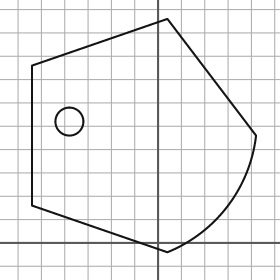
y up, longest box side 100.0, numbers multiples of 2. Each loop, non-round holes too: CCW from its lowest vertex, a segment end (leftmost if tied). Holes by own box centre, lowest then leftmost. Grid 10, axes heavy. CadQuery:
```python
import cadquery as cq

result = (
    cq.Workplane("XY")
    .moveTo(4.0, -4.0)
    .threePointArc((30.0, 16.0), (42.0, 46.0))
    .lineTo(4.0, 96.0)
    .lineTo(-54.0, 76.0)
    .lineTo(-54.0, 16.0)
    .close()
    .moveTo(-38.0, 52.0)
    .circle(6.0)
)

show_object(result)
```